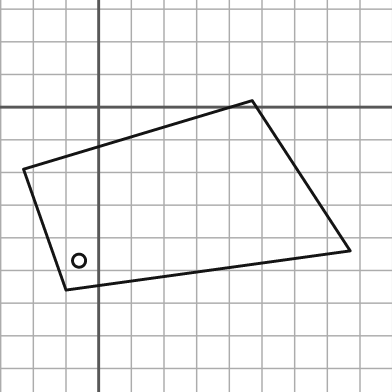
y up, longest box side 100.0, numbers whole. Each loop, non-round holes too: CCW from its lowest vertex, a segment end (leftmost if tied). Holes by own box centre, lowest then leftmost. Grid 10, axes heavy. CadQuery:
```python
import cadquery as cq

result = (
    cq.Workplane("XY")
    .moveTo(-10.0, -56.0)
    .lineTo(77.0, -44.0)
    .lineTo(47.0, 2.0)
    .lineTo(-23.0, -19.0)
    .close()
    .moveTo(-6.0, -47.0)
    .circle(2.0)
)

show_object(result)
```